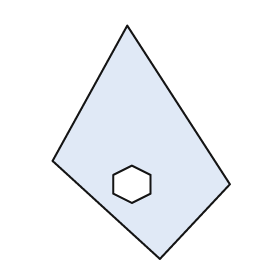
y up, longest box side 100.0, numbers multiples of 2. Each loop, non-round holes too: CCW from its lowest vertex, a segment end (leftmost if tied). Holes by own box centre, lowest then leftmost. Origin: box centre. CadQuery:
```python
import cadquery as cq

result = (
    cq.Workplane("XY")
    .moveTo(8.0, -50.0)
    .lineTo(38.0, -18.0)
    .lineTo(-6.0, 50.0)
    .lineTo(-38.0, -8.0)
    .close()
    .moveTo(-4.0, -26.0)
    .lineTo(4.0, -22.0)
    .lineTo(4.0, -14.0)
    .lineTo(-4.0, -10.0)
    .lineTo(-12.0, -14.0)
    .lineTo(-12.0, -22.0)
    .close()
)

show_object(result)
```